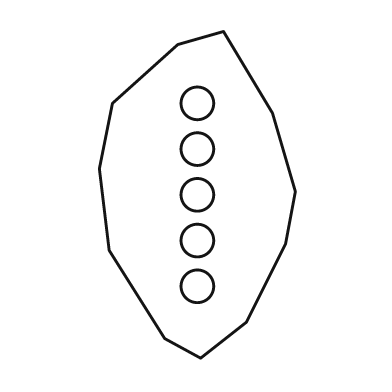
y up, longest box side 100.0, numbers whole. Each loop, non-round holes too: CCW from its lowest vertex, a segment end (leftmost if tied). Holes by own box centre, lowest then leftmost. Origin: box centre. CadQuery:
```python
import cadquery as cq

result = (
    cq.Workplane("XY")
    .moveTo(1.0, -50.0)
    .lineTo(15.0, -39.0)
    .lineTo(27.0, -15.0)
    .lineTo(30.0, 1.0)
    .lineTo(23.0, 25.0)
    .lineTo(8.0, 50.0)
    .lineTo(-6.0, 46.0)
    .lineTo(-26.0, 28.0)
    .lineTo(-30.0, 8.0)
    .lineTo(-27.0, -17.0)
    .lineTo(-10.0, -44.0)
    .close()
    .moveTo(0.0, -28.0)
    .circle(5.0)
    .moveTo(0.0, -14.0)
    .circle(5.0)
    .moveTo(0.0, 0.0)
    .circle(5.0)
    .moveTo(0.0, 14.0)
    .circle(5.0)
    .moveTo(0.0, 28.0)
    .circle(5.0)
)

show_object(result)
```